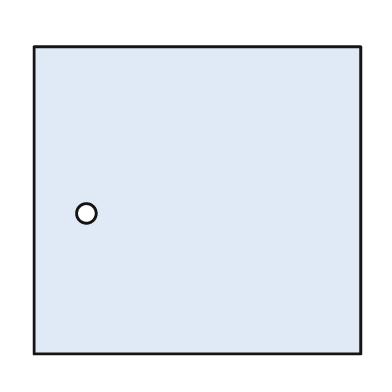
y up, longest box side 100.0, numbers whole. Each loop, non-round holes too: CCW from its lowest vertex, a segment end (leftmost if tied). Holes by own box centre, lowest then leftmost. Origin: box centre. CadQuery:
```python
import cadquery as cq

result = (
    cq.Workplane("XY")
    .moveTo(-50.0, -47.0)
    .lineTo(50.0, -47.0)
    .lineTo(50.0, 47.0)
    .lineTo(-50.0, 47.0)
    .close()
    .moveTo(-34.0, -4.0)
    .circle(3.0)
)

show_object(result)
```